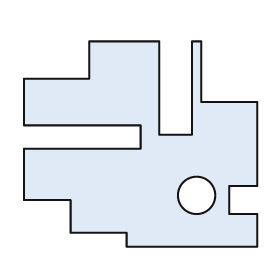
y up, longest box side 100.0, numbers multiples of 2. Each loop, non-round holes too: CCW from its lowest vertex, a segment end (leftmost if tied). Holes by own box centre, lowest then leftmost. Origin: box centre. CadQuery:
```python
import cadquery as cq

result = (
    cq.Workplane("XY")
    .moveTo(-6.0, -44.0)
    .lineTo(50.0, -44.0)
    .lineTo(50.0, -30.0)
    .lineTo(38.0, -30.0)
    .lineTo(38.0, -18.0)
    .lineTo(50.0, -18.0)
    .lineTo(50.0, 18.0)
    .lineTo(26.0, 18.0)
    .lineTo(26.0, 44.0)
    .lineTo(22.0, 44.0)
    .lineTo(22.0, 4.0)
    .lineTo(8.0, 4.0)
    .lineTo(8.0, 44.0)
    .lineTo(-22.0, 44.0)
    .lineTo(-22.0, 28.0)
    .lineTo(-50.0, 28.0)
    .lineTo(-50.0, 8.0)
    .lineTo(0.0, 8.0)
    .lineTo(0.0, -2.0)
    .lineTo(-50.0, -2.0)
    .lineTo(-50.0, -24.0)
    .lineTo(-30.0, -24.0)
    .lineTo(-30.0, -38.0)
    .lineTo(-6.0, -38.0)
    .close()
    .moveTo(24.0, -22.0)
    .circle(8.0)
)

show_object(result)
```